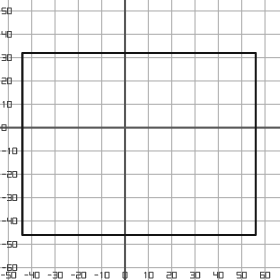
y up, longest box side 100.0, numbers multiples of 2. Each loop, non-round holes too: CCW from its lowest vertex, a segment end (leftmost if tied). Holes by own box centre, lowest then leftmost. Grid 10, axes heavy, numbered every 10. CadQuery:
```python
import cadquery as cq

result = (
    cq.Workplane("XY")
    .moveTo(-44.0, -46.0)
    .lineTo(56.0, -46.0)
    .lineTo(56.0, 32.0)
    .lineTo(-44.0, 32.0)
    .close()
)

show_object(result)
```